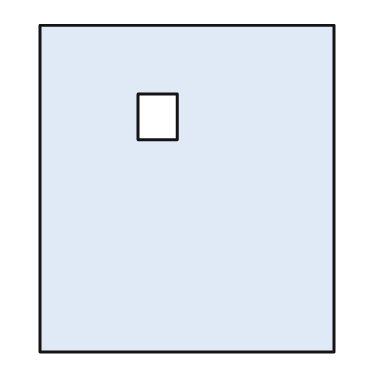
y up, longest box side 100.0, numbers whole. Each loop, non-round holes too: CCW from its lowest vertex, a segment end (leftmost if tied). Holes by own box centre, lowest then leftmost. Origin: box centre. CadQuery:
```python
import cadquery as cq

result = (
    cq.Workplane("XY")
    .moveTo(-45.0, -50.0)
    .lineTo(45.0, -50.0)
    .lineTo(45.0, 50.0)
    .lineTo(-45.0, 50.0)
    .close()
    .moveTo(-15.0, 15.0)
    .lineTo(-3.0, 15.0)
    .lineTo(-3.0, 29.0)
    .lineTo(-15.0, 29.0)
    .close()
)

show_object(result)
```